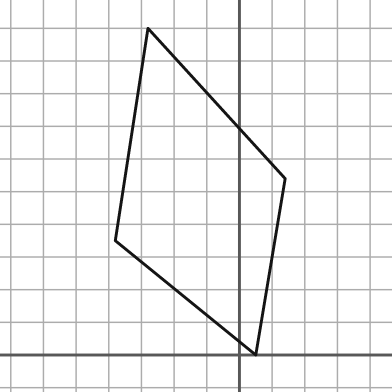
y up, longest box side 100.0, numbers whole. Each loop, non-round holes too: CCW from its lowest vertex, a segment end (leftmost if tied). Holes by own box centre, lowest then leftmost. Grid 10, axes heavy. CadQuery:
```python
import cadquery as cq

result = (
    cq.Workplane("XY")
    .moveTo(5.0, 0.0)
    .lineTo(14.0, 54.0)
    .lineTo(-28.0, 100.0)
    .lineTo(-38.0, 35.0)
    .close()
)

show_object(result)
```